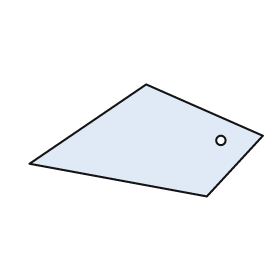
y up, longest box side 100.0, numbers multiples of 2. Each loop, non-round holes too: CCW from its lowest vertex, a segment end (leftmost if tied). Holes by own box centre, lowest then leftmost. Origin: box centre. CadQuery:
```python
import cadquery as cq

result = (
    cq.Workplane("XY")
    .moveTo(26.0, -24.0)
    .lineTo(50.0, 2.0)
    .lineTo(0.0, 24.0)
    .lineTo(-50.0, -10.0)
    .close()
    .moveTo(32.0, 0.0)
    .circle(2.0)
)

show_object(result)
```